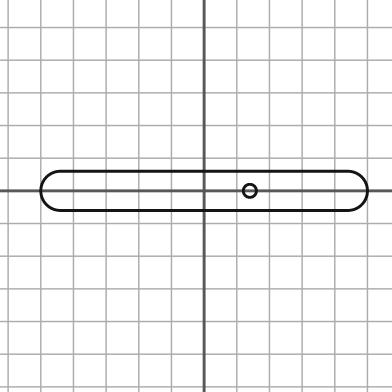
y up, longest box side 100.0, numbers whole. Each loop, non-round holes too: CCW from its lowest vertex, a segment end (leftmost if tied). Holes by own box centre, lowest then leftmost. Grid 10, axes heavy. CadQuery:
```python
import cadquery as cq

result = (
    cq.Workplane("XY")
    .moveTo(-44.0, -6.0)
    .lineTo(44.0, -6.0)
    .threePointArc((50.0, 0.0), (44.0, 6.0))
    .lineTo(-44.0, 6.0)
    .threePointArc((-50.0, 0.0), (-44.0, -6.0))
    .close()
    .moveTo(14.0, 0.0)
    .circle(2.0)
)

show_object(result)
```